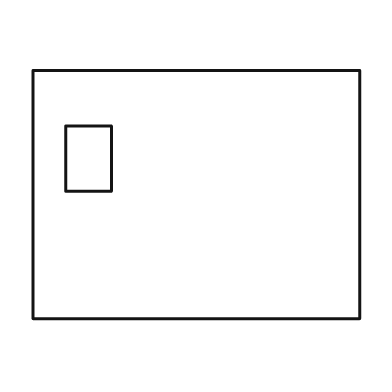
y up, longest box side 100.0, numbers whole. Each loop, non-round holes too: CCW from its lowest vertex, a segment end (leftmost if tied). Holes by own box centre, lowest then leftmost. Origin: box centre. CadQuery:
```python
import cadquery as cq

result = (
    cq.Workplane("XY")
    .moveTo(-50.0, -38.0)
    .lineTo(50.0, -38.0)
    .lineTo(50.0, 38.0)
    .lineTo(-50.0, 38.0)
    .close()
    .moveTo(-40.0, 1.0)
    .lineTo(-26.0, 1.0)
    .lineTo(-26.0, 21.0)
    .lineTo(-40.0, 21.0)
    .close()
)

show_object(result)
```